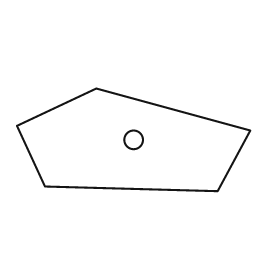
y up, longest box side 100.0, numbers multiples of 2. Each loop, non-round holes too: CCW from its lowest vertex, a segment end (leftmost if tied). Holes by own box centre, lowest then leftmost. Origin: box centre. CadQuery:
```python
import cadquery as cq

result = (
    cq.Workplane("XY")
    .moveTo(36.0, -22.0)
    .lineTo(50.0, 4.0)
    .lineTo(-16.0, 22.0)
    .lineTo(-50.0, 6.0)
    .lineTo(-38.0, -20.0)
    .close()
    .moveTo(0.0, 0.0)
    .circle(4.0)
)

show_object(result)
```